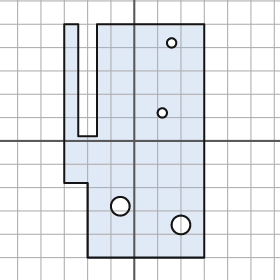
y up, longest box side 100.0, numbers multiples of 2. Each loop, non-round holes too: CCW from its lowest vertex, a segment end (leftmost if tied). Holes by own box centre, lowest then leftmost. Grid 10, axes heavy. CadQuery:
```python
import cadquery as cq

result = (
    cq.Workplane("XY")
    .moveTo(-20.0, -50.0)
    .lineTo(30.0, -50.0)
    .lineTo(30.0, 50.0)
    .lineTo(-16.0, 50.0)
    .lineTo(-16.0, 2.0)
    .lineTo(-24.0, 2.0)
    .lineTo(-24.0, 50.0)
    .lineTo(-30.0, 50.0)
    .lineTo(-30.0, -18.0)
    .lineTo(-20.0, -18.0)
    .close()
    .moveTo(20.0, -36.0)
    .circle(4.0)
    .moveTo(-6.0, -28.0)
    .circle(4.0)
    .moveTo(12.0, 12.0)
    .circle(2.0)
    .moveTo(16.0, 42.0)
    .circle(2.0)
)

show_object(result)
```